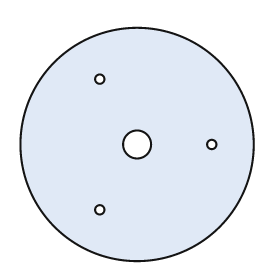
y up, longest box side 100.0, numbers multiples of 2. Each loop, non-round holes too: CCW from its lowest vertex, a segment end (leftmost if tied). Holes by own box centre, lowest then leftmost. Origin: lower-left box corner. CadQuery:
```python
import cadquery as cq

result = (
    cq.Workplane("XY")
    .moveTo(50.0, 50.0)
    .circle(50.0)
    .moveTo(34.0, 22.0)
    .circle(2.0)
    .moveTo(50.0, 50.0)
    .circle(6.0)
    .moveTo(82.0, 50.0)
    .circle(2.0)
    .moveTo(34.0, 78.0)
    .circle(2.0)
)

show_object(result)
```